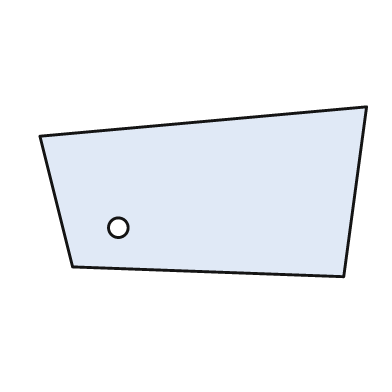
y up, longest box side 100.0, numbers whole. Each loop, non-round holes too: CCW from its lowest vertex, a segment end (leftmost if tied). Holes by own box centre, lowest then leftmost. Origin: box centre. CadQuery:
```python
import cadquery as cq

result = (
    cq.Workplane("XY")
    .moveTo(43.0, -26.0)
    .lineTo(50.0, 26.0)
    .lineTo(-50.0, 17.0)
    .lineTo(-40.0, -23.0)
    .close()
    .moveTo(-26.0, -11.0)
    .circle(3.0)
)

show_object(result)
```